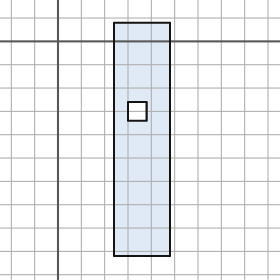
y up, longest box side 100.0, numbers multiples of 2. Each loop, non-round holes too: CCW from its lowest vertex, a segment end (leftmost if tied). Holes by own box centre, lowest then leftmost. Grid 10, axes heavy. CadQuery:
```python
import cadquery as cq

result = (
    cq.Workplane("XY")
    .moveTo(24.0, -92.0)
    .lineTo(48.0, -92.0)
    .lineTo(48.0, 8.0)
    .lineTo(24.0, 8.0)
    .close()
    .moveTo(30.0, -34.0)
    .lineTo(38.0, -34.0)
    .lineTo(38.0, -26.0)
    .lineTo(30.0, -26.0)
    .close()
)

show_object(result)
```